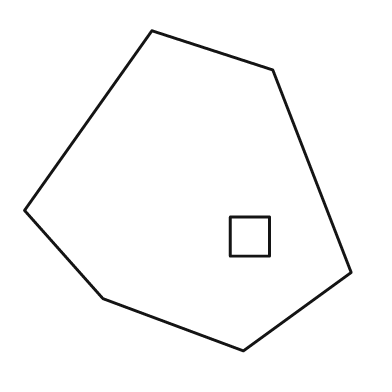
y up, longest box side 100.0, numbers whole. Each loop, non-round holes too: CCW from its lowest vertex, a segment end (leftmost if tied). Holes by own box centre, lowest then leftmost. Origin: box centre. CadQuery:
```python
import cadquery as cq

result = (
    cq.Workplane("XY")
    .moveTo(17.0, -49.0)
    .lineTo(50.0, -25.0)
    .lineTo(26.0, 37.0)
    .lineTo(-11.0, 49.0)
    .lineTo(-50.0, -6.0)
    .lineTo(-26.0, -33.0)
    .close()
    .moveTo(13.0, -20.0)
    .lineTo(25.0, -20.0)
    .lineTo(25.0, -8.0)
    .lineTo(13.0, -8.0)
    .close()
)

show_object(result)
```